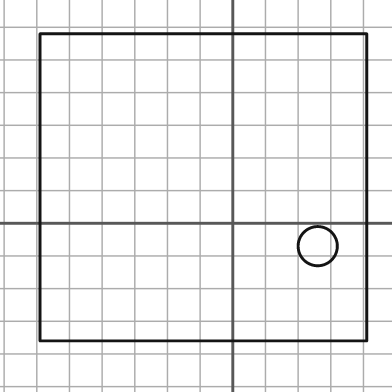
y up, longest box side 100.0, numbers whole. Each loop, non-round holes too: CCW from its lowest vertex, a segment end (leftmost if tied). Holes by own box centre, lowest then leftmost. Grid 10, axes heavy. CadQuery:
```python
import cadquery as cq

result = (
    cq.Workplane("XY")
    .moveTo(-59.0, -36.0)
    .lineTo(41.0, -36.0)
    .lineTo(41.0, 58.0)
    .lineTo(-59.0, 58.0)
    .close()
    .moveTo(26.0, -7.0)
    .circle(6.0)
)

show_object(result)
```